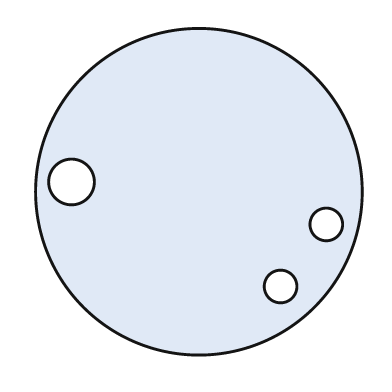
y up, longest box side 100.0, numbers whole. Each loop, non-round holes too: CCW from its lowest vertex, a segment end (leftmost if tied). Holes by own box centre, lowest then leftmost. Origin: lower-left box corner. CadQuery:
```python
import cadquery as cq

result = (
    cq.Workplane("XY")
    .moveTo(50.0, 50.0)
    .circle(50.0)
    .moveTo(75.0, 21.0)
    .circle(5.0)
    .moveTo(89.0, 40.0)
    .circle(5.0)
    .moveTo(11.0, 53.0)
    .circle(7.0)
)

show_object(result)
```